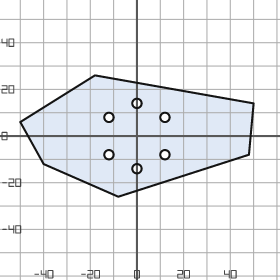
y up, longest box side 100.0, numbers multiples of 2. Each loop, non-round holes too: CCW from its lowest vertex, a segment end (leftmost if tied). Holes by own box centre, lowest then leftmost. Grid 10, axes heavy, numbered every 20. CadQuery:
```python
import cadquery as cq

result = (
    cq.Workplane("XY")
    .moveTo(-8.0, -26.0)
    .lineTo(48.0, -8.0)
    .lineTo(50.0, 14.0)
    .lineTo(-18.0, 26.0)
    .lineTo(-50.0, 6.0)
    .lineTo(-40.0, -12.0)
    .close()
    .moveTo(0.0, -14.0)
    .circle(2.0)
    .moveTo(-12.0, -8.0)
    .circle(2.0)
    .moveTo(12.0, -8.0)
    .circle(2.0)
    .moveTo(-12.0, 8.0)
    .circle(2.0)
    .moveTo(12.0, 8.0)
    .circle(2.0)
    .moveTo(0.0, 14.0)
    .circle(2.0)
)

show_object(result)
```